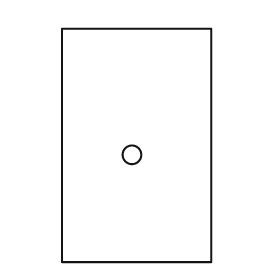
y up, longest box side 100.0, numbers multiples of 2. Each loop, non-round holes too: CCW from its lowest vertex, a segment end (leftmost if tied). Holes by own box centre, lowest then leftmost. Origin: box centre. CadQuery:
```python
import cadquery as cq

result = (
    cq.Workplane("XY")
    .moveTo(-32.0, -50.0)
    .lineTo(32.0, -50.0)
    .lineTo(32.0, 50.0)
    .lineTo(-32.0, 50.0)
    .close()
    .moveTo(-2.0, -4.0)
    .circle(4.0)
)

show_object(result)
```